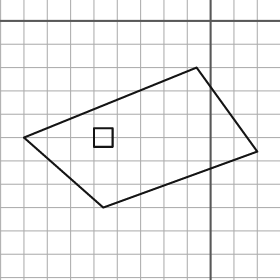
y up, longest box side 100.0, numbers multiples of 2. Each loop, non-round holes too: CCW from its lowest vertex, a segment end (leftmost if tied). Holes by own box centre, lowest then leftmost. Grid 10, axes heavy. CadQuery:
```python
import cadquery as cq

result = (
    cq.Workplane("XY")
    .moveTo(-46.0, -80.0)
    .lineTo(20.0, -56.0)
    .lineTo(-6.0, -20.0)
    .lineTo(-80.0, -50.0)
    .close()
    .moveTo(-50.0, -54.0)
    .lineTo(-42.0, -54.0)
    .lineTo(-42.0, -46.0)
    .lineTo(-50.0, -46.0)
    .close()
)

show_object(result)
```